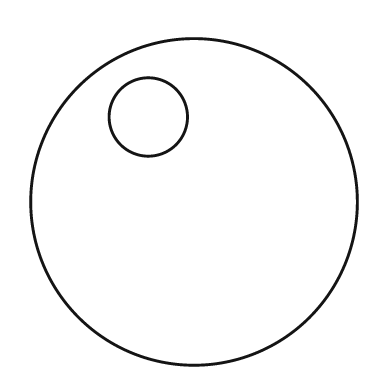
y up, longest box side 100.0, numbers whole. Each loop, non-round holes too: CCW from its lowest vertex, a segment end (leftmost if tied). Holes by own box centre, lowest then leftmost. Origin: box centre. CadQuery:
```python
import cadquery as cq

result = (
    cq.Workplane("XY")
    .moveTo(0.0, 0.0)
    .circle(50.0)
    .moveTo(-14.0, 26.0)
    .circle(12.0)
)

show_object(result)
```